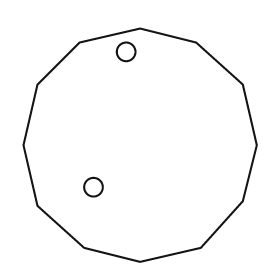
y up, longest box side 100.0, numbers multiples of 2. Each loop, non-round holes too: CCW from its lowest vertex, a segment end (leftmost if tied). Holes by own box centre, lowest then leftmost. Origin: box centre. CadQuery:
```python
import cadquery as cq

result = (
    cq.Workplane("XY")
    .moveTo(0.0, -50.0)
    .lineTo(26.0, -44.0)
    .lineTo(44.0, -24.0)
    .lineTo(50.0, 0.0)
    .lineTo(44.0, 26.0)
    .lineTo(24.0, 44.0)
    .lineTo(0.0, 50.0)
    .lineTo(-26.0, 44.0)
    .lineTo(-44.0, 26.0)
    .lineTo(-50.0, 0.0)
    .lineTo(-44.0, -26.0)
    .lineTo(-24.0, -44.0)
    .close()
    .moveTo(-20.0, -18.0)
    .circle(4.0)
    .moveTo(-6.0, 40.0)
    .circle(4.0)
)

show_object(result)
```